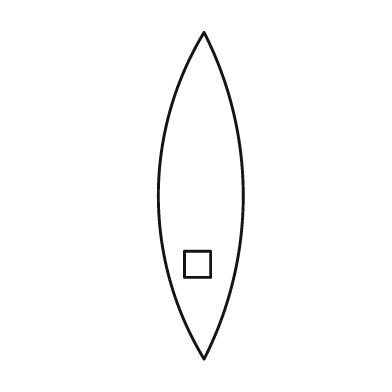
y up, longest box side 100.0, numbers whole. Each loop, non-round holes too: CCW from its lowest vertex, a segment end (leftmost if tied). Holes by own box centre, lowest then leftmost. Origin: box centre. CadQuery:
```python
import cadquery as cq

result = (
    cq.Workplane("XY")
    .moveTo(1.0, -50.0)
    .threePointArc((13.0, 0.0), (1.0, 50.0))
    .threePointArc((-13.0, 0.0), (1.0, -50.0))
    .close()
    .moveTo(-5.0, -25.0)
    .lineTo(3.0, -25.0)
    .lineTo(3.0, -17.0)
    .lineTo(-5.0, -17.0)
    .close()
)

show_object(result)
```